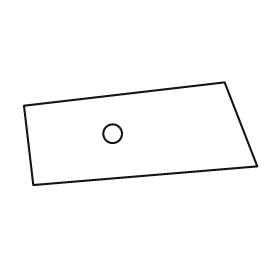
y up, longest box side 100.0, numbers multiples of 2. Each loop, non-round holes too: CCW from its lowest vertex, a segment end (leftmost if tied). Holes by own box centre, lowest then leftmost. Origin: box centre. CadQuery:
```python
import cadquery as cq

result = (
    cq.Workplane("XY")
    .moveTo(-46.0, -22.0)
    .lineTo(50.0, -14.0)
    .lineTo(36.0, 22.0)
    .lineTo(-50.0, 12.0)
    .close()
    .moveTo(-12.0, 0.0)
    .circle(4.0)
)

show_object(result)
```